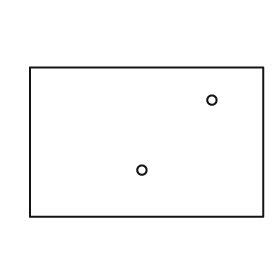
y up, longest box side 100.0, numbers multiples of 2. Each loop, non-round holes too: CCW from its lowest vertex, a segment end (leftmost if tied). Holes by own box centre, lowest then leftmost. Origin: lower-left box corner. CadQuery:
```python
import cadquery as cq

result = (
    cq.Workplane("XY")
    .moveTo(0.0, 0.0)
    .lineTo(100.0, 0.0)
    .lineTo(100.0, 64.0)
    .lineTo(0.0, 64.0)
    .close()
    .moveTo(48.0, 20.0)
    .circle(2.0)
    .moveTo(78.0, 50.0)
    .circle(2.0)
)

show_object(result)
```